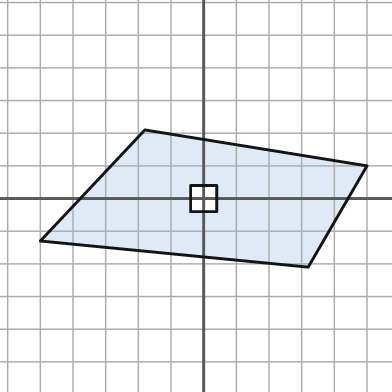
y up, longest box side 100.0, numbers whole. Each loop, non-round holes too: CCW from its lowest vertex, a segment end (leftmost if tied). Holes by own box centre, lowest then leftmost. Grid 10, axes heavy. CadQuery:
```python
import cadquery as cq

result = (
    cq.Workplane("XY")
    .moveTo(32.0, -21.0)
    .lineTo(50.0, 10.0)
    .lineTo(-18.0, 21.0)
    .lineTo(-50.0, -13.0)
    .close()
    .moveTo(-4.0, -4.0)
    .lineTo(4.0, -4.0)
    .lineTo(4.0, 4.0)
    .lineTo(-4.0, 4.0)
    .close()
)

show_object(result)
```